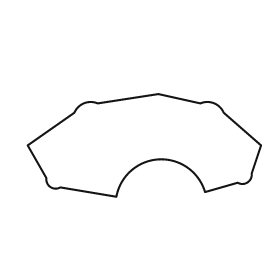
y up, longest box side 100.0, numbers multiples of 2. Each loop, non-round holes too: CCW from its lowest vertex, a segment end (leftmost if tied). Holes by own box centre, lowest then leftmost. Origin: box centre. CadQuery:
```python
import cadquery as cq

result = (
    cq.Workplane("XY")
    .moveTo(-12.0, -22.0)
    .threePointArc((6.0, -6.0), (26.0, -20.0))
    .lineTo(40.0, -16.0)
    .threePointArc((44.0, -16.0), (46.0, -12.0))
    .lineTo(50.0, 0.0)
    .lineTo(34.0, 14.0)
    .threePointArc((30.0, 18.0), (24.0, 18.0))
    .lineTo(6.0, 22.0)
    .lineTo(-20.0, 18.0)
    .threePointArc((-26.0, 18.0), (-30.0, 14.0))
    .lineTo(-50.0, 0.0)
    .lineTo(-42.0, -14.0)
    .threePointArc((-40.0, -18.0), (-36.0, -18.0))
    .close()
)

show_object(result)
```